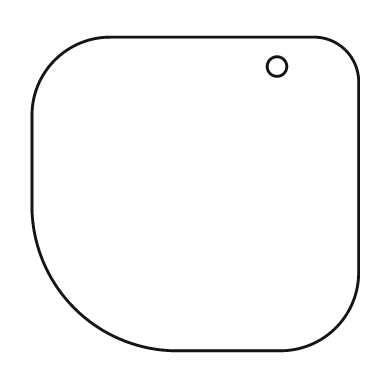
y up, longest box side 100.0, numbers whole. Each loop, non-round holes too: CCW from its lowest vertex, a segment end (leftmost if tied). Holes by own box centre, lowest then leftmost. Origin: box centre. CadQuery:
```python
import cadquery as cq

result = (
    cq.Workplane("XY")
    .moveTo(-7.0, -48.0)
    .lineTo(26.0, -48.0)
    .threePointArc((43.0, -41.0), (50.0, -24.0))
    .lineTo(50.0, 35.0)
    .threePointArc((46.0, 44.0), (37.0, 48.0))
    .lineTo(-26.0, 48.0)
    .threePointArc((-43.0, 41.0), (-50.0, 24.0))
    .lineTo(-50.0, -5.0)
    .threePointArc((-37.0, -35.0), (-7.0, -48.0))
    .close()
    .moveTo(25.0, 39.0)
    .circle(3.0)
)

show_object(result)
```